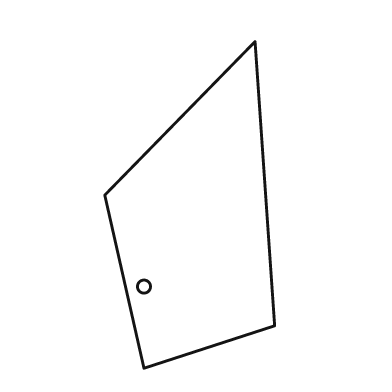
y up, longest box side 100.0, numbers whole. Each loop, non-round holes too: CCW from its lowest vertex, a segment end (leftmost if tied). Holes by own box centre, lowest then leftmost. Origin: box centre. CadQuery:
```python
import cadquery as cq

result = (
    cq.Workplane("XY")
    .moveTo(-14.0, -50.0)
    .lineTo(26.0, -37.0)
    .lineTo(20.0, 50.0)
    .lineTo(-26.0, 3.0)
    .close()
    .moveTo(-14.0, -25.0)
    .circle(2.0)
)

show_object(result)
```